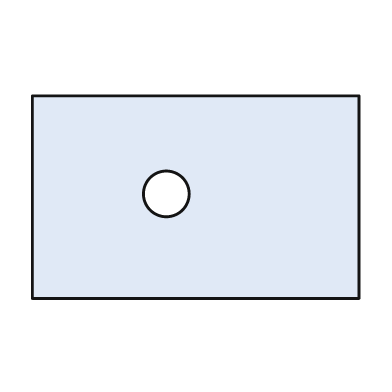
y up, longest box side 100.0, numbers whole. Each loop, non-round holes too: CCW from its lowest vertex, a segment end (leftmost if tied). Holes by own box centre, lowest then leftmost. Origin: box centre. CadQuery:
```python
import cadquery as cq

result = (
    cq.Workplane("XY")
    .moveTo(-50.0, -31.0)
    .lineTo(50.0, -31.0)
    .lineTo(50.0, 31.0)
    .lineTo(-50.0, 31.0)
    .close()
    .moveTo(-9.0, 1.0)
    .circle(7.0)
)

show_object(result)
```